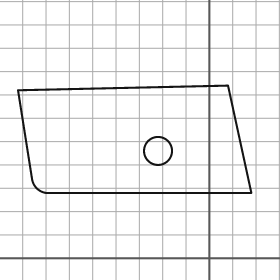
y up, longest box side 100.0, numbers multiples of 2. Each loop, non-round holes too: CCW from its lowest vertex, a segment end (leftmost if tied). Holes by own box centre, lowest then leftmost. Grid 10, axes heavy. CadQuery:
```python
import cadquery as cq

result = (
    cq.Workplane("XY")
    .moveTo(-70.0, 28.0)
    .lineTo(18.0, 28.0)
    .lineTo(8.0, 74.0)
    .lineTo(-82.0, 72.0)
    .lineTo(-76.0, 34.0)
    .threePointArc((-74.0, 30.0), (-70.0, 28.0))
    .close()
    .moveTo(-22.0, 46.0)
    .circle(6.0)
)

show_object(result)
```